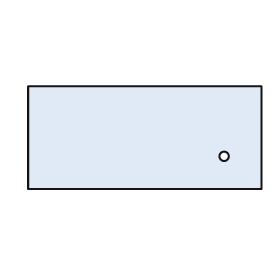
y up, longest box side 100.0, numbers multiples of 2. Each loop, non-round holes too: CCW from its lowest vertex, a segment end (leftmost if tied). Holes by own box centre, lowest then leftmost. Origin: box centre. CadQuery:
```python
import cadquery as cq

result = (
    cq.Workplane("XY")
    .moveTo(-50.0, -22.0)
    .lineTo(50.0, -22.0)
    .lineTo(50.0, 22.0)
    .lineTo(-50.0, 22.0)
    .close()
    .moveTo(34.0, -8.0)
    .circle(2.0)
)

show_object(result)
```